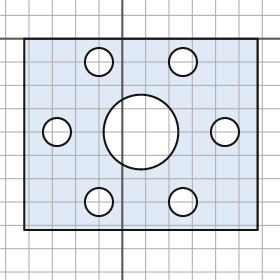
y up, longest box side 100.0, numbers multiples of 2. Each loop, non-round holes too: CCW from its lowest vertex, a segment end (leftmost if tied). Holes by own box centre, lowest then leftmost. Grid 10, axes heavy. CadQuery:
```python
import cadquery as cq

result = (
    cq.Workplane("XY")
    .moveTo(-42.0, -82.0)
    .lineTo(58.0, -82.0)
    .lineTo(58.0, 0.0)
    .lineTo(-42.0, 0.0)
    .close()
    .moveTo(-10.0, -70.0)
    .circle(6.0)
    .moveTo(26.0, -70.0)
    .circle(6.0)
    .moveTo(-28.0, -40.0)
    .circle(6.0)
    .moveTo(8.0, -40.0)
    .circle(16.0)
    .moveTo(44.0, -40.0)
    .circle(6.0)
    .moveTo(-10.0, -10.0)
    .circle(6.0)
    .moveTo(26.0, -10.0)
    .circle(6.0)
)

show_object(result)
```